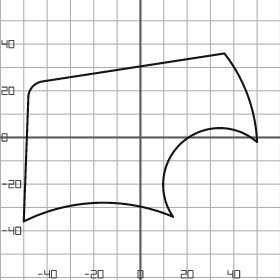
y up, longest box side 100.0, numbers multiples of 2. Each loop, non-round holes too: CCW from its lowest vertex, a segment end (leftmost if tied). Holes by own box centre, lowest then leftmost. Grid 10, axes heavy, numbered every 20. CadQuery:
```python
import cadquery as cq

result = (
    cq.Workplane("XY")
    .moveTo(-50.0, -36.0)
    .threePointArc((-18.0, -28.0), (14.0, -34.0))
    .threePointArc((18.0, -2.0), (50.0, -2.0))
    .threePointArc((46.0, 18.0), (36.0, 36.0))
    .lineTo(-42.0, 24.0)
    .threePointArc((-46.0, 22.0), (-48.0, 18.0))
    .close()
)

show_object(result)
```